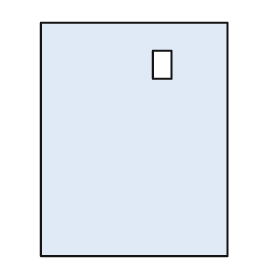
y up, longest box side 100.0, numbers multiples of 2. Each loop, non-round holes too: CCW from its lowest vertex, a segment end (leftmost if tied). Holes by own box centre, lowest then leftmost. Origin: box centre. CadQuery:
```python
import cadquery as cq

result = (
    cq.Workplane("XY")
    .moveTo(-40.0, -50.0)
    .lineTo(40.0, -50.0)
    .lineTo(40.0, 50.0)
    .lineTo(-40.0, 50.0)
    .close()
    .moveTo(8.0, 26.0)
    .lineTo(16.0, 26.0)
    .lineTo(16.0, 38.0)
    .lineTo(8.0, 38.0)
    .close()
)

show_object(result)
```